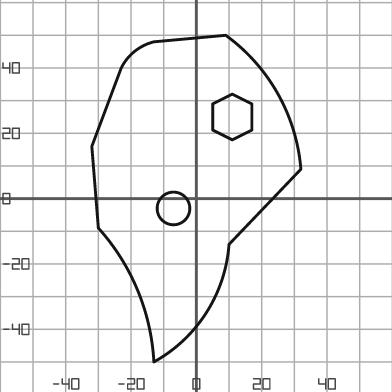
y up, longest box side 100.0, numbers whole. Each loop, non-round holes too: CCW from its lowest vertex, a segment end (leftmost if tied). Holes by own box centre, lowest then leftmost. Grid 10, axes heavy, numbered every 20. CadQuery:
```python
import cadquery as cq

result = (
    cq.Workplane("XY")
    .moveTo(-13.0, -50.0)
    .threePointArc((3.0, -35.0), (10.0, -14.0))
    .lineTo(32.0, 9.0)
    .threePointArc((25.0, 32.0), (9.0, 50.0))
    .lineTo(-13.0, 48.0)
    .threePointArc((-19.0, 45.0), (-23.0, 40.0))
    .lineTo(-32.0, 16.0)
    .lineTo(-30.0, -9.0)
    .threePointArc((-18.0, -28.0), (-13.0, -50.0))
    .close()
    .moveTo(-7.0, -3.0)
    .circle(5.0)
    .moveTo(11.0, 18.0)
    .lineTo(17.0, 21.0)
    .lineTo(17.0, 29.0)
    .lineTo(11.0, 32.0)
    .lineTo(5.0, 29.0)
    .lineTo(5.0, 21.0)
    .close()
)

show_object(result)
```